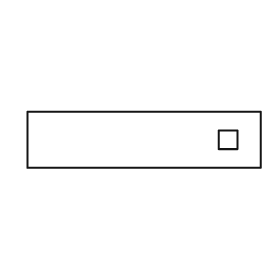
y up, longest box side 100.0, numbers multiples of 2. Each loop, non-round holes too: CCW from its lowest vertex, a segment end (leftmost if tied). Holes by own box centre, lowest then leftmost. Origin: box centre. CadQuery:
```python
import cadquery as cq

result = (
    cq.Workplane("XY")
    .moveTo(-50.0, -12.0)
    .lineTo(50.0, -12.0)
    .lineTo(50.0, 12.0)
    .lineTo(-50.0, 12.0)
    .close()
    .moveTo(32.0, -4.0)
    .lineTo(40.0, -4.0)
    .lineTo(40.0, 4.0)
    .lineTo(32.0, 4.0)
    .close()
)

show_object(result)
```